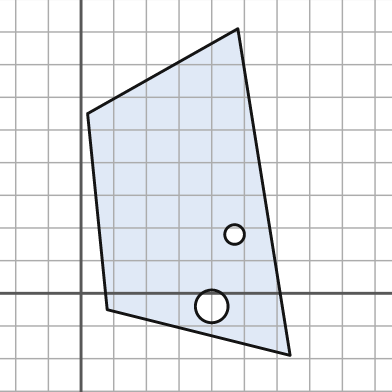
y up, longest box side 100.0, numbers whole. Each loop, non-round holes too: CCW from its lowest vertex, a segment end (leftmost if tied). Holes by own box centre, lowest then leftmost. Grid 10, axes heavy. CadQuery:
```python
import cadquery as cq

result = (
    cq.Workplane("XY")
    .moveTo(64.0, -19.0)
    .lineTo(48.0, 81.0)
    .lineTo(2.0, 55.0)
    .lineTo(8.0, -5.0)
    .close()
    .moveTo(40.0, -4.0)
    .circle(5.0)
    .moveTo(47.0, 18.0)
    .circle(3.0)
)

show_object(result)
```